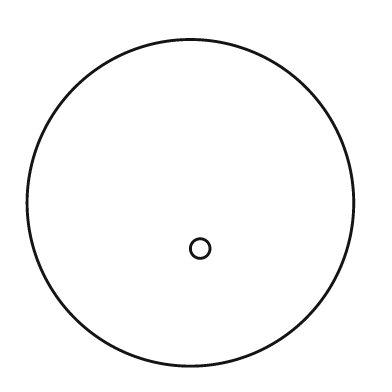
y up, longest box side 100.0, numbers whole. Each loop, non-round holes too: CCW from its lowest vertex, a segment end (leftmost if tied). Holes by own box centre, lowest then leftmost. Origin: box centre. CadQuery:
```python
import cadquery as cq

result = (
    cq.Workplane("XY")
    .moveTo(0.0, 0.0)
    .circle(50.0)
    .moveTo(3.0, -14.0)
    .circle(3.0)
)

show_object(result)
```